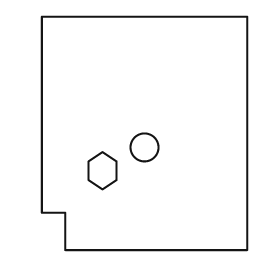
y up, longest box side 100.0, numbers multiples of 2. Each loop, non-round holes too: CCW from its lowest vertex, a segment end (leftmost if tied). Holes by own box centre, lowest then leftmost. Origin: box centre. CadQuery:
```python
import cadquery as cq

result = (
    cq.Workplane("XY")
    .moveTo(-34.0, -50.0)
    .lineTo(44.0, -50.0)
    .lineTo(44.0, 50.0)
    .lineTo(-44.0, 50.0)
    .lineTo(-44.0, -34.0)
    .lineTo(-34.0, -34.0)
    .close()
    .moveTo(-18.0, -24.0)
    .lineTo(-12.0, -20.0)
    .lineTo(-12.0, -12.0)
    .lineTo(-18.0, -8.0)
    .lineTo(-24.0, -12.0)
    .lineTo(-24.0, -20.0)
    .close()
    .moveTo(0.0, -6.0)
    .circle(6.0)
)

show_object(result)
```